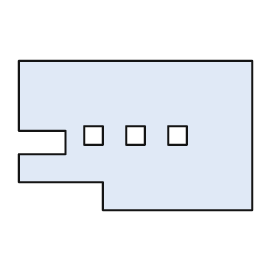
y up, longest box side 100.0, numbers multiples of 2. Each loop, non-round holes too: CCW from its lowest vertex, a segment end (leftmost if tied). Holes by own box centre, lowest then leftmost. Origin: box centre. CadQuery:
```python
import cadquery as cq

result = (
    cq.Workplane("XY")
    .moveTo(-14.0, -32.0)
    .lineTo(50.0, -32.0)
    .lineTo(50.0, 32.0)
    .lineTo(-50.0, 32.0)
    .lineTo(-50.0, 2.0)
    .lineTo(-30.0, 2.0)
    .lineTo(-30.0, -8.0)
    .lineTo(-50.0, -8.0)
    .lineTo(-50.0, -20.0)
    .lineTo(-14.0, -20.0)
    .close()
    .moveTo(-22.0, -4.0)
    .lineTo(-14.0, -4.0)
    .lineTo(-14.0, 4.0)
    .lineTo(-22.0, 4.0)
    .close()
    .moveTo(-4.0, -4.0)
    .lineTo(4.0, -4.0)
    .lineTo(4.0, 4.0)
    .lineTo(-4.0, 4.0)
    .close()
    .moveTo(14.0, -4.0)
    .lineTo(22.0, -4.0)
    .lineTo(22.0, 4.0)
    .lineTo(14.0, 4.0)
    .close()
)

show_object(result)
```